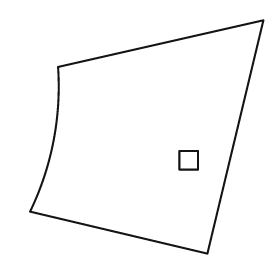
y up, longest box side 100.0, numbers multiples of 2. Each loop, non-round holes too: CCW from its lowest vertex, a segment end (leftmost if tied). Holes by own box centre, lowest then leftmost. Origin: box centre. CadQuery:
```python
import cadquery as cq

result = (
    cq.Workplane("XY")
    .moveTo(26.0, -50.0)
    .lineTo(50.0, 50.0)
    .lineTo(-38.0, 30.0)
    .threePointArc((-40.0, -2.0), (-50.0, -32.0))
    .close()
    .moveTo(14.0, -14.0)
    .lineTo(22.0, -14.0)
    .lineTo(22.0, -6.0)
    .lineTo(14.0, -6.0)
    .close()
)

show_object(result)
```